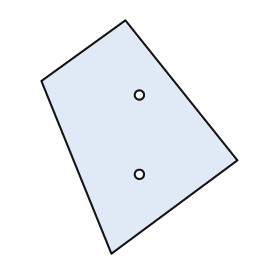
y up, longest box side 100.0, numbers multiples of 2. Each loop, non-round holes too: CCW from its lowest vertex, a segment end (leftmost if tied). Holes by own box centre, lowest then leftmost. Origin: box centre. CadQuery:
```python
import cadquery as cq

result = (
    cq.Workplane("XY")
    .moveTo(-12.0, -50.0)
    .lineTo(42.0, -10.0)
    .lineTo(-6.0, 50.0)
    .lineTo(-42.0, 24.0)
    .close()
    .moveTo(0.0, -16.0)
    .circle(2.0)
    .moveTo(0.0, 18.0)
    .circle(2.0)
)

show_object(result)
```